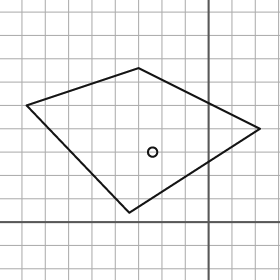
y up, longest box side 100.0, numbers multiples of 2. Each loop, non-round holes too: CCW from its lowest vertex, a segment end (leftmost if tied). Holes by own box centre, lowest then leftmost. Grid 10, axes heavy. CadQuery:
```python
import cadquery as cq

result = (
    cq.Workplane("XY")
    .moveTo(-34.0, 4.0)
    .lineTo(22.0, 40.0)
    .lineTo(-30.0, 66.0)
    .lineTo(-78.0, 50.0)
    .close()
    .moveTo(-24.0, 30.0)
    .circle(2.0)
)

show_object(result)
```